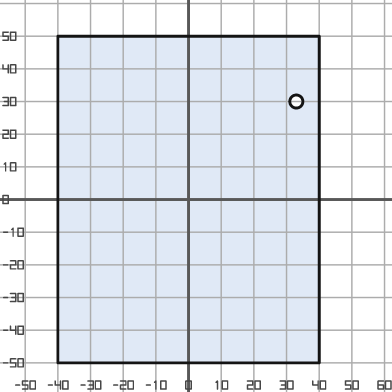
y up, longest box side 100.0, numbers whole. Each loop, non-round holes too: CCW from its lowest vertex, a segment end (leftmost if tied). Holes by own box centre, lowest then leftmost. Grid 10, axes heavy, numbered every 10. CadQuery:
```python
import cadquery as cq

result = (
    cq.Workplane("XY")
    .moveTo(-40.0, -50.0)
    .lineTo(40.0, -50.0)
    .lineTo(40.0, 50.0)
    .lineTo(-40.0, 50.0)
    .close()
    .moveTo(33.0, 30.0)
    .circle(2.0)
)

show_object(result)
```